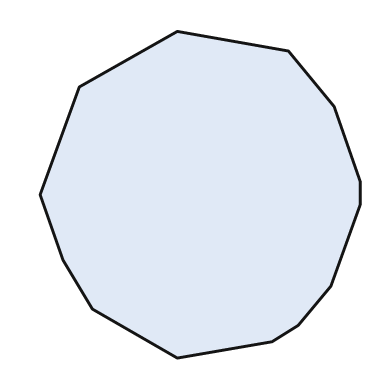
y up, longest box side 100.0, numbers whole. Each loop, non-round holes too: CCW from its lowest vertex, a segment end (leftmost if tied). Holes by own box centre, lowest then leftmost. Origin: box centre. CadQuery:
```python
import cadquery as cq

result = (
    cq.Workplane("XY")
    .moveTo(-7.0, -50.0)
    .lineTo(22.0, -45.0)
    .lineTo(30.0, -40.0)
    .lineTo(40.0, -28.0)
    .lineTo(49.0, -3.0)
    .lineTo(49.0, 4.0)
    .lineTo(41.0, 27.0)
    .lineTo(27.0, 44.0)
    .lineTo(-7.0, 50.0)
    .lineTo(-37.0, 33.0)
    .lineTo(-49.0, 0.0)
    .lineTo(-42.0, -20.0)
    .lineTo(-33.0, -35.0)
    .close()
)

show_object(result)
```